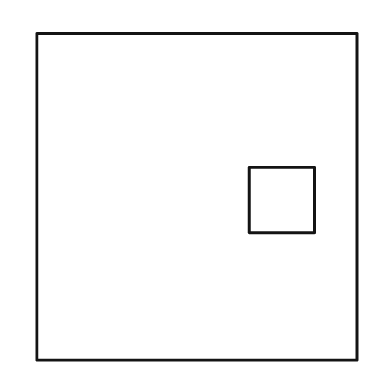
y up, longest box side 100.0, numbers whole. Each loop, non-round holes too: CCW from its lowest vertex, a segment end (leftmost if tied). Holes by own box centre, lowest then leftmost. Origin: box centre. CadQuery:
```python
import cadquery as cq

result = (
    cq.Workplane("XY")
    .moveTo(-49.0, -50.0)
    .lineTo(49.0, -50.0)
    .lineTo(49.0, 50.0)
    .lineTo(-49.0, 50.0)
    .close()
    .moveTo(16.0, -11.0)
    .lineTo(36.0, -11.0)
    .lineTo(36.0, 9.0)
    .lineTo(16.0, 9.0)
    .close()
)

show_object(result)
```